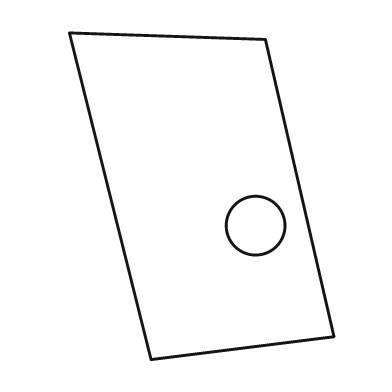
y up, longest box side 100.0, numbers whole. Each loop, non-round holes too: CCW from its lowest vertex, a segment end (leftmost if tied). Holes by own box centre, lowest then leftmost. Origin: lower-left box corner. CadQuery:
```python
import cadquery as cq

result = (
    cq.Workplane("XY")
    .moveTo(25.0, 0.0)
    .lineTo(81.0, 7.0)
    .lineTo(60.0, 98.0)
    .lineTo(0.0, 100.0)
    .close()
    .moveTo(57.0, 41.0)
    .circle(9.0)
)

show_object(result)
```